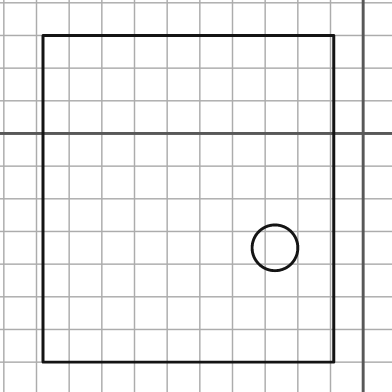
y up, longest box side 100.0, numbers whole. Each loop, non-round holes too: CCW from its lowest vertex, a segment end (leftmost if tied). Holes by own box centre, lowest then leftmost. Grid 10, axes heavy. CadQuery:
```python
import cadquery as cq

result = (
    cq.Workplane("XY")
    .moveTo(-98.0, -70.0)
    .lineTo(-9.0, -70.0)
    .lineTo(-9.0, 30.0)
    .lineTo(-98.0, 30.0)
    .close()
    .moveTo(-27.0, -35.0)
    .circle(7.0)
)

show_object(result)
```